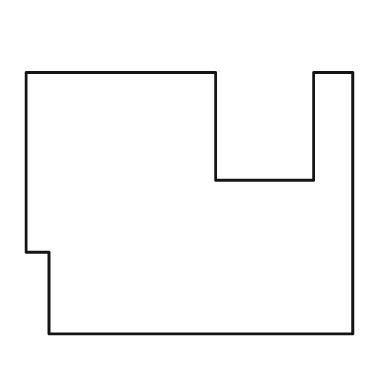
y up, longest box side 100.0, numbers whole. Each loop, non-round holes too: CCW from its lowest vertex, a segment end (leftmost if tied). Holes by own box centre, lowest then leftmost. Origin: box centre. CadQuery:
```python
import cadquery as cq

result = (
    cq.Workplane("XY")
    .moveTo(-43.0, -40.0)
    .lineTo(50.0, -40.0)
    .lineTo(50.0, 40.0)
    .lineTo(38.0, 40.0)
    .lineTo(38.0, 7.0)
    .lineTo(8.0, 7.0)
    .lineTo(8.0, 40.0)
    .lineTo(-50.0, 40.0)
    .lineTo(-50.0, -15.0)
    .lineTo(-43.0, -15.0)
    .close()
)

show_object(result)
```